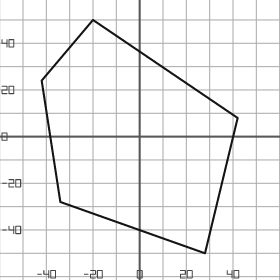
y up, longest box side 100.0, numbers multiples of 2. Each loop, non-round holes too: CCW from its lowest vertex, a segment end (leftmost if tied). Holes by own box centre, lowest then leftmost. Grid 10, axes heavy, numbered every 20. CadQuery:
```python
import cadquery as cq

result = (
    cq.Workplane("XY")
    .moveTo(28.0, -50.0)
    .lineTo(42.0, 8.0)
    .lineTo(-20.0, 50.0)
    .lineTo(-42.0, 24.0)
    .lineTo(-34.0, -28.0)
    .close()
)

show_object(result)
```